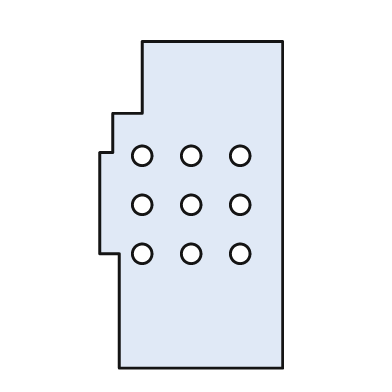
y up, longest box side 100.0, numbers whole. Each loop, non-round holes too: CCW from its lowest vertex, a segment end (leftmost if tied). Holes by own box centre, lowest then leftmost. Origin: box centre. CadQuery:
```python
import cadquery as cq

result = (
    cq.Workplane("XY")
    .moveTo(-22.0, -50.0)
    .lineTo(28.0, -50.0)
    .lineTo(28.0, 50.0)
    .lineTo(-15.0, 50.0)
    .lineTo(-15.0, 28.0)
    .lineTo(-24.0, 28.0)
    .lineTo(-24.0, 16.0)
    .lineTo(-28.0, 16.0)
    .lineTo(-28.0, -15.0)
    .lineTo(-22.0, -15.0)
    .close()
    .moveTo(-15.0, -15.0)
    .circle(3.0)
    .moveTo(0.0, -15.0)
    .circle(3.0)
    .moveTo(15.0, -15.0)
    .circle(3.0)
    .moveTo(-15.0, 0.0)
    .circle(3.0)
    .moveTo(0.0, 0.0)
    .circle(3.0)
    .moveTo(15.0, 0.0)
    .circle(3.0)
    .moveTo(-15.0, 15.0)
    .circle(3.0)
    .moveTo(0.0, 15.0)
    .circle(3.0)
    .moveTo(15.0, 15.0)
    .circle(3.0)
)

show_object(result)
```